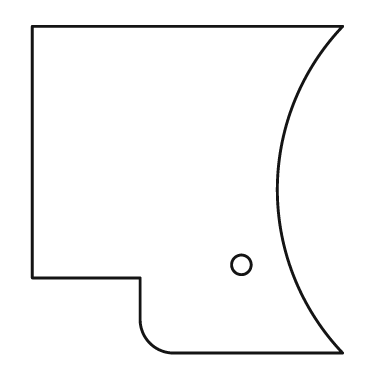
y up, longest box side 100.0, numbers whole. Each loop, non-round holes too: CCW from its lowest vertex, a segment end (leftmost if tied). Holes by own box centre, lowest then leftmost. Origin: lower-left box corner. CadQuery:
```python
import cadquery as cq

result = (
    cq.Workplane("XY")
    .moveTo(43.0, 0.0)
    .lineTo(95.0, 0.0)
    .threePointArc((75.0, 50.0), (95.0, 100.0))
    .lineTo(0.0, 100.0)
    .lineTo(0.0, 23.0)
    .lineTo(33.0, 23.0)
    .lineTo(33.0, 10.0)
    .threePointArc((36.0, 3.0), (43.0, 0.0))
    .close()
    .moveTo(64.0, 27.0)
    .circle(3.0)
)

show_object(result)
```